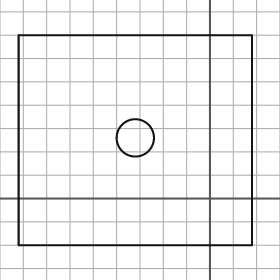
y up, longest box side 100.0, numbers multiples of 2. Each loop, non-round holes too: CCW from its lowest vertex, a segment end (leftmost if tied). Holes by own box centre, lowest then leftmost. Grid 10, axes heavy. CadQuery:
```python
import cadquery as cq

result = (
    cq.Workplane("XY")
    .moveTo(-82.0, -20.0)
    .lineTo(18.0, -20.0)
    .lineTo(18.0, 70.0)
    .lineTo(-82.0, 70.0)
    .close()
    .moveTo(-32.0, 26.0)
    .circle(8.0)
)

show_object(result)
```